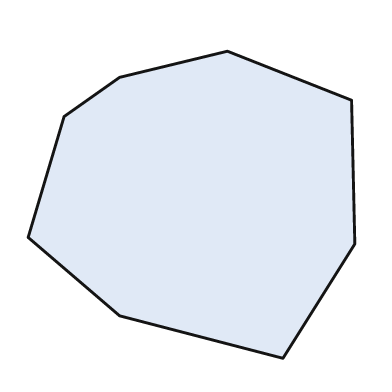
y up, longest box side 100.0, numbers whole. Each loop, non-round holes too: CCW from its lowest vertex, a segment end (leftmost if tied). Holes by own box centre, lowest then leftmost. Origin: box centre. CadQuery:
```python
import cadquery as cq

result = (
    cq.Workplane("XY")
    .moveTo(28.0, -47.0)
    .lineTo(50.0, -12.0)
    .lineTo(49.0, 32.0)
    .lineTo(11.0, 47.0)
    .lineTo(-22.0, 39.0)
    .lineTo(-39.0, 27.0)
    .lineTo(-50.0, -10.0)
    .lineTo(-22.0, -34.0)
    .close()
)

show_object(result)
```